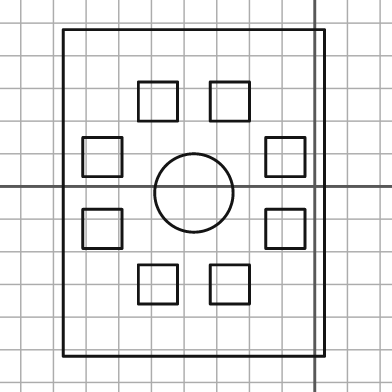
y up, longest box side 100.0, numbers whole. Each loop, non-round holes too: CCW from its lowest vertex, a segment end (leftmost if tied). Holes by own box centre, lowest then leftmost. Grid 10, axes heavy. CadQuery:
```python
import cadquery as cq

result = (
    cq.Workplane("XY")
    .moveTo(-77.0, -52.0)
    .lineTo(3.0, -52.0)
    .lineTo(3.0, 48.0)
    .lineTo(-77.0, 48.0)
    .close()
    .moveTo(-54.0, -36.0)
    .lineTo(-42.0, -36.0)
    .lineTo(-42.0, -24.0)
    .lineTo(-54.0, -24.0)
    .close()
    .moveTo(-32.0, -36.0)
    .lineTo(-20.0, -36.0)
    .lineTo(-20.0, -24.0)
    .lineTo(-32.0, -24.0)
    .close()
    .moveTo(-71.0, -19.0)
    .lineTo(-59.0, -19.0)
    .lineTo(-59.0, -7.0)
    .lineTo(-71.0, -7.0)
    .close()
    .moveTo(-15.0, -19.0)
    .lineTo(-3.0, -19.0)
    .lineTo(-3.0, -7.0)
    .lineTo(-15.0, -7.0)
    .close()
    .moveTo(-37.0, -2.0)
    .circle(12.0)
    .moveTo(-71.0, 3.0)
    .lineTo(-59.0, 3.0)
    .lineTo(-59.0, 15.0)
    .lineTo(-71.0, 15.0)
    .close()
    .moveTo(-15.0, 3.0)
    .lineTo(-3.0, 3.0)
    .lineTo(-3.0, 15.0)
    .lineTo(-15.0, 15.0)
    .close()
    .moveTo(-54.0, 20.0)
    .lineTo(-42.0, 20.0)
    .lineTo(-42.0, 32.0)
    .lineTo(-54.0, 32.0)
    .close()
    .moveTo(-32.0, 20.0)
    .lineTo(-20.0, 20.0)
    .lineTo(-20.0, 32.0)
    .lineTo(-32.0, 32.0)
    .close()
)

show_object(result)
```